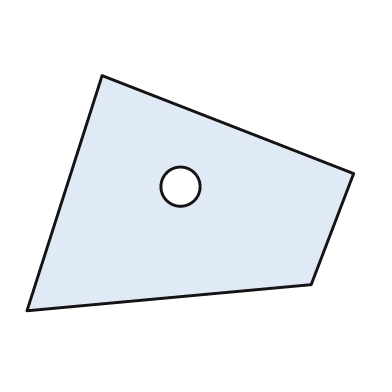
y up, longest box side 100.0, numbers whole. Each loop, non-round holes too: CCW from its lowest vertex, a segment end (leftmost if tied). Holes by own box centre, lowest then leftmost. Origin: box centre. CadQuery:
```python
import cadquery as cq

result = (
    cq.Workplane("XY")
    .moveTo(-50.0, -36.0)
    .lineTo(37.0, -28.0)
    .lineTo(50.0, 6.0)
    .lineTo(-27.0, 36.0)
    .close()
    .moveTo(-3.0, 2.0)
    .circle(6.0)
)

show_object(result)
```